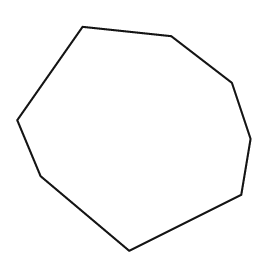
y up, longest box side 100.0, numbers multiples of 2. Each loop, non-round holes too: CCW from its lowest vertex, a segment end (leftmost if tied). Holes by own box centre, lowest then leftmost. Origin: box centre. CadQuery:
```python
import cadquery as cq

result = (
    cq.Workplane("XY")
    .moveTo(-2.0, -48.0)
    .lineTo(46.0, -24.0)
    .lineTo(50.0, 0.0)
    .lineTo(42.0, 24.0)
    .lineTo(16.0, 44.0)
    .lineTo(-22.0, 48.0)
    .lineTo(-50.0, 8.0)
    .lineTo(-40.0, -16.0)
    .close()
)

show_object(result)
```